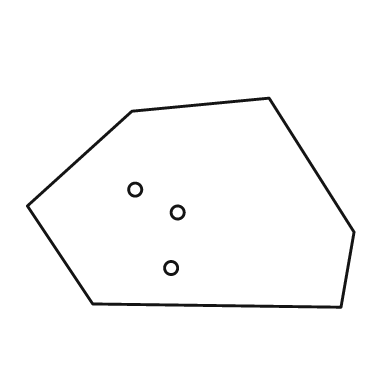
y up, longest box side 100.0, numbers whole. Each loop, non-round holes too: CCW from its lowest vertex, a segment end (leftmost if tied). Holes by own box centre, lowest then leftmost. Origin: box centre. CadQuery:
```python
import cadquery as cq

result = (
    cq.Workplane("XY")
    .moveTo(46.0, -32.0)
    .lineTo(50.0, -9.0)
    .lineTo(24.0, 32.0)
    .lineTo(-18.0, 28.0)
    .lineTo(-50.0, -1.0)
    .lineTo(-30.0, -31.0)
    .close()
    .moveTo(-6.0, -20.0)
    .circle(2.0)
    .moveTo(-4.0, -3.0)
    .circle(2.0)
    .moveTo(-17.0, 4.0)
    .circle(2.0)
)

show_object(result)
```